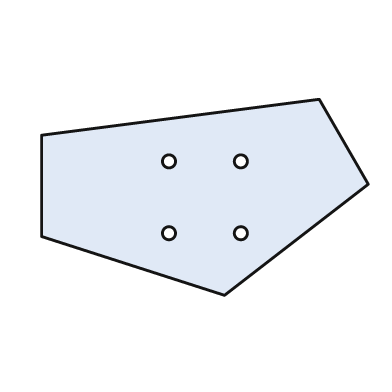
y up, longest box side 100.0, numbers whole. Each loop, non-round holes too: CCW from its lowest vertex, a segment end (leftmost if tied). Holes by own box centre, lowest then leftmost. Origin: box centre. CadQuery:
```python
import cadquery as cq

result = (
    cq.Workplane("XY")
    .moveTo(6.0, -30.0)
    .lineTo(50.0, 4.0)
    .lineTo(35.0, 30.0)
    .lineTo(-50.0, 19.0)
    .lineTo(-50.0, -12.0)
    .close()
    .moveTo(-11.0, -11.0)
    .circle(2.0)
    .moveTo(11.0, -11.0)
    .circle(2.0)
    .moveTo(-11.0, 11.0)
    .circle(2.0)
    .moveTo(11.0, 11.0)
    .circle(2.0)
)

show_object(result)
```